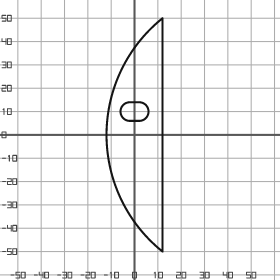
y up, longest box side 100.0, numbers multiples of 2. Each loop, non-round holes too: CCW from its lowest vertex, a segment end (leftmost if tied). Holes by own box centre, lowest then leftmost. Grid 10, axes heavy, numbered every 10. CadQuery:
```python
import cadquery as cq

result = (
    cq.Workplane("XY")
    .moveTo(12.0, -50.0)
    .lineTo(12.0, 50.0)
    .threePointArc((-12.0, 0.0), (12.0, -50.0))
    .close()
    .moveTo(-2.0, 6.0)
    .lineTo(2.0, 6.0)
    .threePointArc((6.0, 10.0), (2.0, 14.0))
    .lineTo(-2.0, 14.0)
    .threePointArc((-6.0, 10.0), (-2.0, 6.0))
    .close()
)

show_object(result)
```